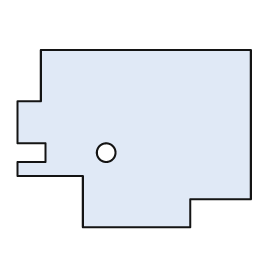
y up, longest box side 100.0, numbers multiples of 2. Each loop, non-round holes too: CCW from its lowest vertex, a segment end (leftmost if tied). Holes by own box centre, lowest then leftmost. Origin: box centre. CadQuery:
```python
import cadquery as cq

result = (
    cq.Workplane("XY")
    .moveTo(-22.0, -38.0)
    .lineTo(24.0, -38.0)
    .lineTo(24.0, -26.0)
    .lineTo(50.0, -26.0)
    .lineTo(50.0, 38.0)
    .lineTo(-40.0, 38.0)
    .lineTo(-40.0, 16.0)
    .lineTo(-50.0, 16.0)
    .lineTo(-50.0, -2.0)
    .lineTo(-38.0, -2.0)
    .lineTo(-38.0, -10.0)
    .lineTo(-50.0, -10.0)
    .lineTo(-50.0, -16.0)
    .lineTo(-22.0, -16.0)
    .close()
    .moveTo(-12.0, -6.0)
    .circle(4.0)
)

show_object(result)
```